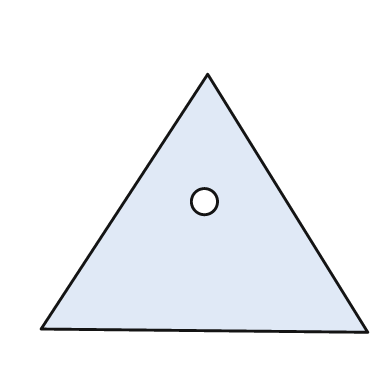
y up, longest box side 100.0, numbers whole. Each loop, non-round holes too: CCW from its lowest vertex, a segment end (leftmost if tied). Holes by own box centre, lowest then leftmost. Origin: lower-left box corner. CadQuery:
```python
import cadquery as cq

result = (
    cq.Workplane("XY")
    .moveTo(100.0, 0.0)
    .lineTo(51.0, 79.0)
    .lineTo(0.0, 1.0)
    .close()
    .moveTo(50.0, 40.0)
    .circle(4.0)
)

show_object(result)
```